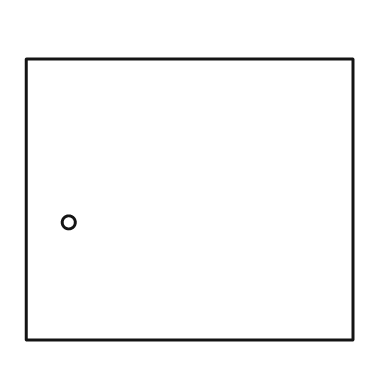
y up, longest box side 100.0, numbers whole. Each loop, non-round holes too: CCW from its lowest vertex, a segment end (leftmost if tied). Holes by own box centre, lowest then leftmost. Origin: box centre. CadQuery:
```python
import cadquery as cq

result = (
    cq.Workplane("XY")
    .moveTo(-50.0, -43.0)
    .lineTo(50.0, -43.0)
    .lineTo(50.0, 43.0)
    .lineTo(-50.0, 43.0)
    .close()
    .moveTo(-37.0, -7.0)
    .circle(2.0)
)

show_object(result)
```